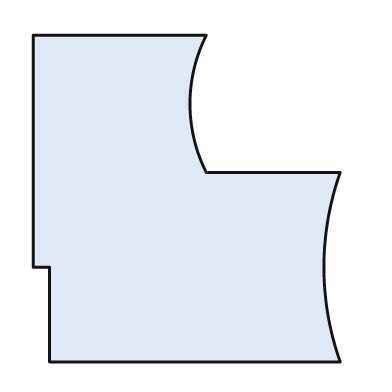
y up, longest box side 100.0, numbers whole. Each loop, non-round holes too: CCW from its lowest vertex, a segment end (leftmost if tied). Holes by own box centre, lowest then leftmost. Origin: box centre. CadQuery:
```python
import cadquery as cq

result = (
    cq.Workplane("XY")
    .moveTo(-42.0, -50.0)
    .lineTo(47.0, -50.0)
    .threePointArc((42.0, -21.0), (47.0, 8.0))
    .lineTo(6.0, 8.0)
    .threePointArc((1.0, 29.0), (6.0, 50.0))
    .lineTo(-47.0, 50.0)
    .lineTo(-47.0, -21.0)
    .lineTo(-42.0, -21.0)
    .close()
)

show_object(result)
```